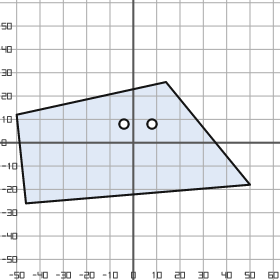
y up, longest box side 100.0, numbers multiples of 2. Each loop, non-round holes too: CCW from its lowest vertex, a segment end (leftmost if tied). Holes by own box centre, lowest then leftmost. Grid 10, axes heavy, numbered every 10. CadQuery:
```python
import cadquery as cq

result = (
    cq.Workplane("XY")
    .moveTo(-46.0, -26.0)
    .lineTo(50.0, -18.0)
    .lineTo(14.0, 26.0)
    .lineTo(-50.0, 12.0)
    .close()
    .moveTo(-4.0, 8.0)
    .circle(2.0)
    .moveTo(8.0, 8.0)
    .circle(2.0)
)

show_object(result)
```